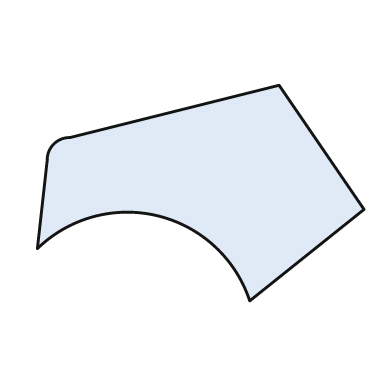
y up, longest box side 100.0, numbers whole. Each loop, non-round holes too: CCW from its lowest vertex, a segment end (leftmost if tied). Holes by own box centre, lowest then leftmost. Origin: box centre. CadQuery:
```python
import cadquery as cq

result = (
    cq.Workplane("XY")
    .moveTo(15.0, -33.0)
    .lineTo(50.0, -5.0)
    .lineTo(24.0, 33.0)
    .lineTo(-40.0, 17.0)
    .threePointArc((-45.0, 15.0), (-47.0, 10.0))
    .lineTo(-50.0, -17.0)
    .threePointArc((-13.0, -7.0), (15.0, -33.0))
    .close()
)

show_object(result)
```